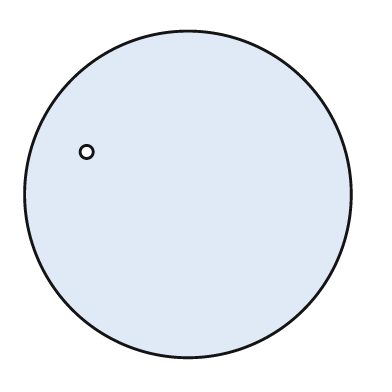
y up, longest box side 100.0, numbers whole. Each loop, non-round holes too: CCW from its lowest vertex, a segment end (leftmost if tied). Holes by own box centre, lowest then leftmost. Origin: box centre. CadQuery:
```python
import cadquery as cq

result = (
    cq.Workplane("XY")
    .moveTo(0.0, 0.0)
    .circle(50.0)
    .moveTo(-31.0, 13.0)
    .circle(2.0)
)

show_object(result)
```